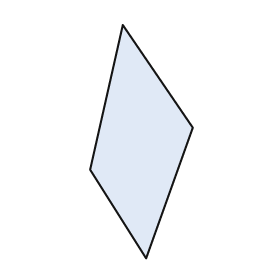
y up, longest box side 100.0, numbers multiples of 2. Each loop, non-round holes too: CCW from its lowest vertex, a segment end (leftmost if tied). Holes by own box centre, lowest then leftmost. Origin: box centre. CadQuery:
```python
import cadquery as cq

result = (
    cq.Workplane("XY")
    .moveTo(2.0, -50.0)
    .lineTo(22.0, 6.0)
    .lineTo(-8.0, 50.0)
    .lineTo(-22.0, -12.0)
    .close()
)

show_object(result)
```